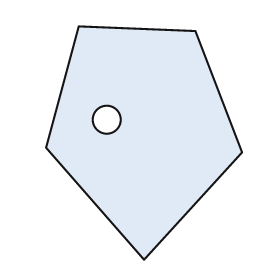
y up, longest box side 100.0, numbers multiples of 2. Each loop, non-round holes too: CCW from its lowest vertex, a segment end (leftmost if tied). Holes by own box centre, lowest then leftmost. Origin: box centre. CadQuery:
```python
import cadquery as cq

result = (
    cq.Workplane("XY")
    .moveTo(0.0, -50.0)
    .lineTo(42.0, -4.0)
    .lineTo(22.0, 48.0)
    .lineTo(-28.0, 50.0)
    .lineTo(-42.0, -2.0)
    .close()
    .moveTo(-16.0, 10.0)
    .circle(6.0)
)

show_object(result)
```